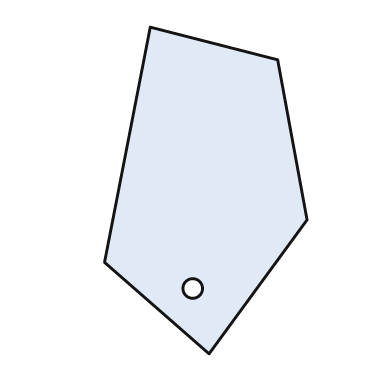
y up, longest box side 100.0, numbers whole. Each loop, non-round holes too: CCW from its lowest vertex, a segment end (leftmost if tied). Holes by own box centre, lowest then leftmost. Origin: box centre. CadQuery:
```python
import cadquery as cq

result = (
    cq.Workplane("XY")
    .moveTo(1.0, -50.0)
    .lineTo(31.0, -9.0)
    .lineTo(22.0, 40.0)
    .lineTo(-17.0, 50.0)
    .lineTo(-31.0, -22.0)
    .close()
    .moveTo(-4.0, -30.0)
    .circle(3.0)
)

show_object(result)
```